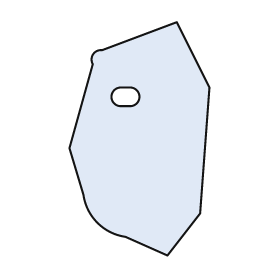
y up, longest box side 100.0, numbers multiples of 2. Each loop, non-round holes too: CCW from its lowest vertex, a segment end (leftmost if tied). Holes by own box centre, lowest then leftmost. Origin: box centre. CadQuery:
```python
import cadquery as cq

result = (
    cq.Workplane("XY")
    .moveTo(12.0, -50.0)
    .lineTo(26.0, -32.0)
    .lineTo(30.0, 22.0)
    .lineTo(16.0, 50.0)
    .lineTo(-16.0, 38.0)
    .threePointArc((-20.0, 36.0), (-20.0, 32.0))
    .lineTo(-30.0, -4.0)
    .lineTo(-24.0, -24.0)
    .threePointArc((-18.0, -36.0), (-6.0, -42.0))
    .close()
    .moveTo(-8.0, 14.0)
    .lineTo(-4.0, 14.0)
    .threePointArc((0.0, 18.0), (-4.0, 22.0))
    .lineTo(-8.0, 22.0)
    .threePointArc((-12.0, 18.0), (-8.0, 14.0))
    .close()
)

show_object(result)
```